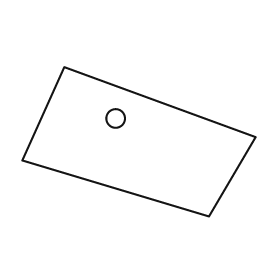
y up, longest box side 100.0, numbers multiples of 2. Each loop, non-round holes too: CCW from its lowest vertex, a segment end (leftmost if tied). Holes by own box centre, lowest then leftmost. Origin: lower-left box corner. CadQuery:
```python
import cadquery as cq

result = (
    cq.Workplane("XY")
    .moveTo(80.0, 0.0)
    .lineTo(100.0, 34.0)
    .lineTo(18.0, 64.0)
    .lineTo(0.0, 24.0)
    .close()
    .moveTo(40.0, 42.0)
    .circle(4.0)
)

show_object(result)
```